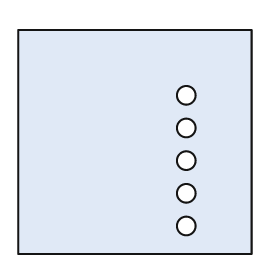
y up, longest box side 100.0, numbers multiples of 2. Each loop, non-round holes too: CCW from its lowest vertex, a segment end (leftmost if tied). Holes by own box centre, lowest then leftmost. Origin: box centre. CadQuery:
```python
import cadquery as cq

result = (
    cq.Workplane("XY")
    .moveTo(-50.0, -48.0)
    .lineTo(50.0, -48.0)
    .lineTo(50.0, 48.0)
    .lineTo(-50.0, 48.0)
    .close()
    .moveTo(22.0, -36.0)
    .circle(4.0)
    .moveTo(22.0, -22.0)
    .circle(4.0)
    .moveTo(22.0, -8.0)
    .circle(4.0)
    .moveTo(22.0, 6.0)
    .circle(4.0)
    .moveTo(22.0, 20.0)
    .circle(4.0)
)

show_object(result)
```